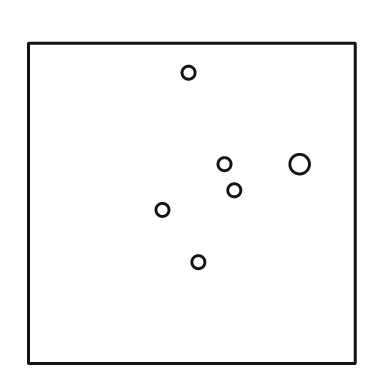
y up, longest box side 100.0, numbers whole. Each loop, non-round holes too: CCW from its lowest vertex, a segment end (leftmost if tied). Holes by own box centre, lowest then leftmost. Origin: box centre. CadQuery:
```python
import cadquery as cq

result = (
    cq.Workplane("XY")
    .moveTo(-50.0, -49.0)
    .lineTo(50.0, -49.0)
    .lineTo(50.0, 49.0)
    .lineTo(-50.0, 49.0)
    .close()
    .moveTo(2.0, -18.0)
    .circle(2.0)
    .moveTo(-9.0, -2.0)
    .circle(2.0)
    .moveTo(13.0, 4.0)
    .circle(2.0)
    .moveTo(10.0, 12.0)
    .circle(2.0)
    .moveTo(33.0, 12.0)
    .circle(3.0)
    .moveTo(-1.0, 40.0)
    .circle(2.0)
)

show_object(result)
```